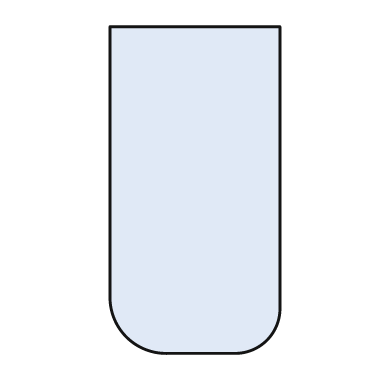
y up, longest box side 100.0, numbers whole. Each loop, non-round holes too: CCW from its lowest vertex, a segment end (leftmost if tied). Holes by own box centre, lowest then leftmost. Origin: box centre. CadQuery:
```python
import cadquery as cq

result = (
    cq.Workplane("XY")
    .moveTo(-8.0, -50.0)
    .lineTo(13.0, -50.0)
    .threePointArc((22.0, -46.0), (26.0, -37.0))
    .lineTo(26.0, 50.0)
    .lineTo(-26.0, 50.0)
    .lineTo(-26.0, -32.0)
    .threePointArc((-21.0, -45.0), (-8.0, -50.0))
    .close()
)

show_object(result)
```